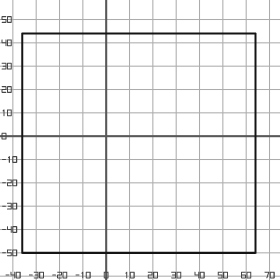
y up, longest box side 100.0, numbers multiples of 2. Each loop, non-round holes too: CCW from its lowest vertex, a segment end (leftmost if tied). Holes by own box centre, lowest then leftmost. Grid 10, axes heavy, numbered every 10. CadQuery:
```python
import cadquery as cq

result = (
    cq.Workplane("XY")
    .moveTo(-36.0, -50.0)
    .lineTo(64.0, -50.0)
    .lineTo(64.0, 44.0)
    .lineTo(-36.0, 44.0)
    .close()
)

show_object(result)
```